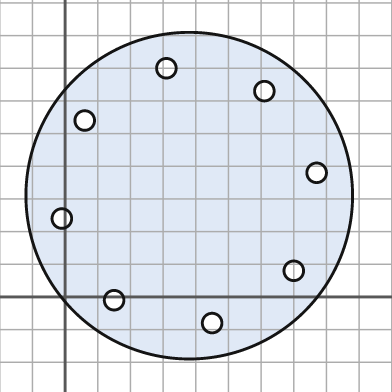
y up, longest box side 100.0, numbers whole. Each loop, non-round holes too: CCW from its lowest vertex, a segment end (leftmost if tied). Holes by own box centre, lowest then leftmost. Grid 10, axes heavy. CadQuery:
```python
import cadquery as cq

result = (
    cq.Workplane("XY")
    .moveTo(38.0, 31.0)
    .circle(50.0)
    .moveTo(45.0, -8.0)
    .circle(3.0)
    .moveTo(15.0, -1.0)
    .circle(3.0)
    .moveTo(70.0, 8.0)
    .circle(3.0)
    .moveTo(-1.0, 24.0)
    .circle(3.0)
    .moveTo(77.0, 38.0)
    .circle(3.0)
    .moveTo(6.0, 54.0)
    .circle(3.0)
    .moveTo(61.0, 63.0)
    .circle(3.0)
    .moveTo(31.0, 70.0)
    .circle(3.0)
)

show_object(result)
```